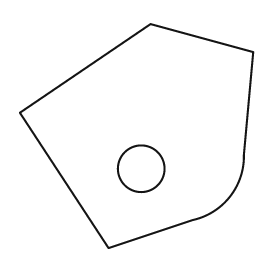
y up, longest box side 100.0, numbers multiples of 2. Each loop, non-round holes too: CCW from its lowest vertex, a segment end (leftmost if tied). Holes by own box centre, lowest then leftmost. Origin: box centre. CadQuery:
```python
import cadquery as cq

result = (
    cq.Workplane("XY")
    .moveTo(-12.0, -48.0)
    .lineTo(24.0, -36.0)
    .threePointArc((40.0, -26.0), (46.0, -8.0))
    .lineTo(50.0, 36.0)
    .lineTo(6.0, 48.0)
    .lineTo(-50.0, 10.0)
    .close()
    .moveTo(2.0, -14.0)
    .circle(10.0)
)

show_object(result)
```